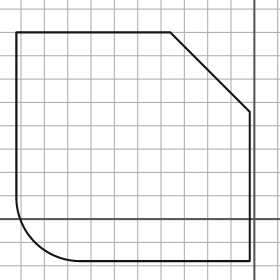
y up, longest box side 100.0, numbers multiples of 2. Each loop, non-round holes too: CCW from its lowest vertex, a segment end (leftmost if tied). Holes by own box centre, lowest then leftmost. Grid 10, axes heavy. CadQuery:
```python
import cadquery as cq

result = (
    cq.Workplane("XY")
    .moveTo(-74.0, -18.0)
    .lineTo(-2.0, -18.0)
    .lineTo(-2.0, 46.0)
    .lineTo(-36.0, 80.0)
    .lineTo(-102.0, 80.0)
    .lineTo(-102.0, 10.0)
    .threePointArc((-94.0, -10.0), (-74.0, -18.0))
    .close()
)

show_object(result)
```